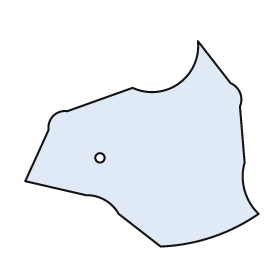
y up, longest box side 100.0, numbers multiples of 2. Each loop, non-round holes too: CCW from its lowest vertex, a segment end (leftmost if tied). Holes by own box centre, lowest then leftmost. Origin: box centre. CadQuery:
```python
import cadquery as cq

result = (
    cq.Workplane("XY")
    .moveTo(8.0, -44.0)
    .threePointArc((30.0, -40.0), (50.0, -30.0))
    .threePointArc((44.0, -20.0), (44.0, -8.0))
    .lineTo(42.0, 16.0)
    .threePointArc((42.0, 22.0), (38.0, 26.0))
    .lineTo(24.0, 44.0)
    .threePointArc((16.0, 26.0), (-4.0, 24.0))
    .lineTo(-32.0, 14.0)
    .threePointArc((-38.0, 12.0), (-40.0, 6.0))
    .lineTo(-50.0, -16.0)
    .lineTo(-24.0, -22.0)
    .threePointArc((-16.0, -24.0), (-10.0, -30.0))
    .close()
    .moveTo(-18.0, -6.0)
    .circle(2.0)
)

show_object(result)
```